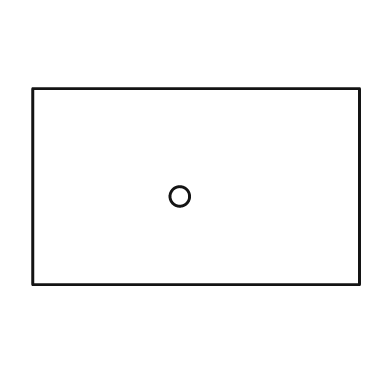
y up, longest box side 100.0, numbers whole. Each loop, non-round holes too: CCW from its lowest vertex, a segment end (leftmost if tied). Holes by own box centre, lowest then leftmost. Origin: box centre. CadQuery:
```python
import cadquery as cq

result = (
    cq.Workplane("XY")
    .moveTo(-50.0, -30.0)
    .lineTo(50.0, -30.0)
    .lineTo(50.0, 30.0)
    .lineTo(-50.0, 30.0)
    .close()
    .moveTo(-5.0, -3.0)
    .circle(3.0)
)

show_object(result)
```